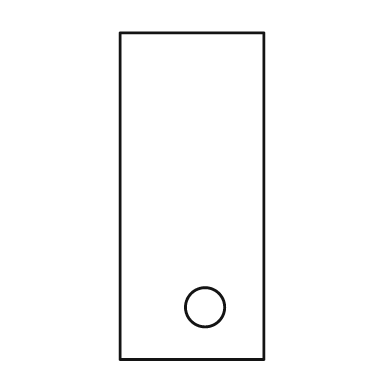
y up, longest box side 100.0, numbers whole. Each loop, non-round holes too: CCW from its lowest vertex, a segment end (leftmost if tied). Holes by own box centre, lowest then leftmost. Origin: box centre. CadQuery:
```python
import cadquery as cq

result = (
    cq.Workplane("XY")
    .moveTo(-22.0, -50.0)
    .lineTo(22.0, -50.0)
    .lineTo(22.0, 50.0)
    .lineTo(-22.0, 50.0)
    .close()
    .moveTo(4.0, -34.0)
    .circle(6.0)
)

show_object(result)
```